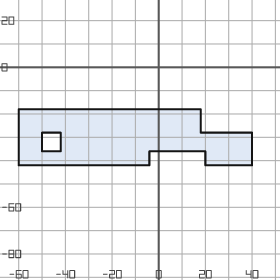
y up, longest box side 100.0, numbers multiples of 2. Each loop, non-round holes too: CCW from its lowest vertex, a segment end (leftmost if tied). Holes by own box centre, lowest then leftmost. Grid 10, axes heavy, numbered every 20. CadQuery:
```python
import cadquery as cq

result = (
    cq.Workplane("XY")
    .moveTo(-60.0, -42.0)
    .lineTo(-4.0, -42.0)
    .lineTo(-4.0, -36.0)
    .lineTo(20.0, -36.0)
    .lineTo(20.0, -42.0)
    .lineTo(40.0, -42.0)
    .lineTo(40.0, -28.0)
    .lineTo(18.0, -28.0)
    .lineTo(18.0, -18.0)
    .lineTo(-60.0, -18.0)
    .close()
    .moveTo(-50.0, -36.0)
    .lineTo(-42.0, -36.0)
    .lineTo(-42.0, -28.0)
    .lineTo(-50.0, -28.0)
    .close()
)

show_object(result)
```